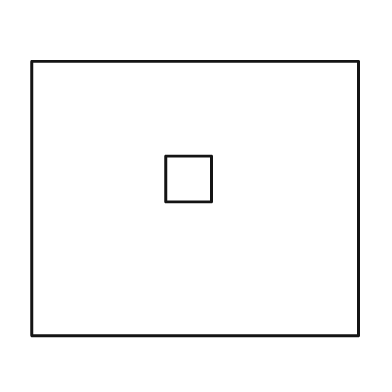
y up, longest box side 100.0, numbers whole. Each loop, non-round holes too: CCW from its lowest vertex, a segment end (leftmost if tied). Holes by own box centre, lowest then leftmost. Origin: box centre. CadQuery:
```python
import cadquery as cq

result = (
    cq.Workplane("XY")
    .moveTo(-50.0, -42.0)
    .lineTo(50.0, -42.0)
    .lineTo(50.0, 42.0)
    .lineTo(-50.0, 42.0)
    .close()
    .moveTo(-9.0, -1.0)
    .lineTo(5.0, -1.0)
    .lineTo(5.0, 13.0)
    .lineTo(-9.0, 13.0)
    .close()
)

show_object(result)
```